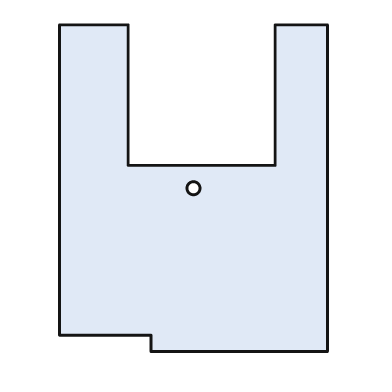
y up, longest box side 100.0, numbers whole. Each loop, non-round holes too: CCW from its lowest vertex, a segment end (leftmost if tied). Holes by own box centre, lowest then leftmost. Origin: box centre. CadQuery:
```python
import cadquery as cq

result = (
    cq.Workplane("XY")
    .moveTo(-13.0, -50.0)
    .lineTo(41.0, -50.0)
    .lineTo(41.0, 50.0)
    .lineTo(25.0, 50.0)
    .lineTo(25.0, 7.0)
    .lineTo(-20.0, 7.0)
    .lineTo(-20.0, 50.0)
    .lineTo(-41.0, 50.0)
    .lineTo(-41.0, -45.0)
    .lineTo(-13.0, -45.0)
    .close()
    .moveTo(0.0, 0.0)
    .circle(2.0)
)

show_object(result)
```